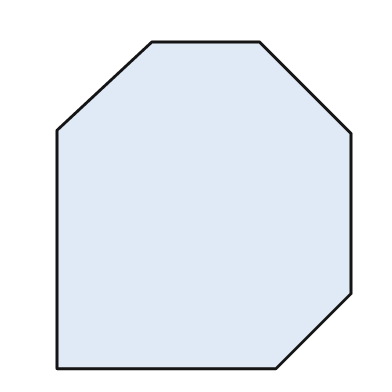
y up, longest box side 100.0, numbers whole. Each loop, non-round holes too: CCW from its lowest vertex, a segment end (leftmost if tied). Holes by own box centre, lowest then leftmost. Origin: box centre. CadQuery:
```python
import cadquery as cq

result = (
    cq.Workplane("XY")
    .moveTo(-45.0, -50.0)
    .lineTo(22.0, -50.0)
    .lineTo(45.0, -27.0)
    .lineTo(45.0, 22.0)
    .lineTo(17.0, 50.0)
    .lineTo(-16.0, 50.0)
    .lineTo(-45.0, 23.0)
    .close()
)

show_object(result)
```